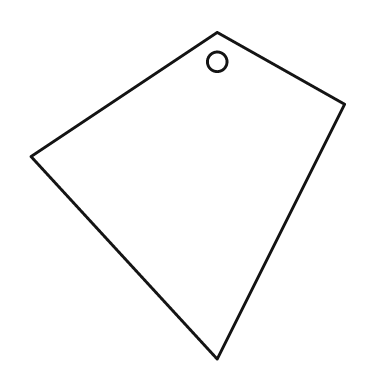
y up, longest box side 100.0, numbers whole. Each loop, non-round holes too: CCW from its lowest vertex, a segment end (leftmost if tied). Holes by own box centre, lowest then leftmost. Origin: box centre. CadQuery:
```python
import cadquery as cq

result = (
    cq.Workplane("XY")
    .moveTo(9.0, -50.0)
    .lineTo(48.0, 28.0)
    .lineTo(9.0, 50.0)
    .lineTo(-48.0, 12.0)
    .close()
    .moveTo(9.0, 41.0)
    .circle(3.0)
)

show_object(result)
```